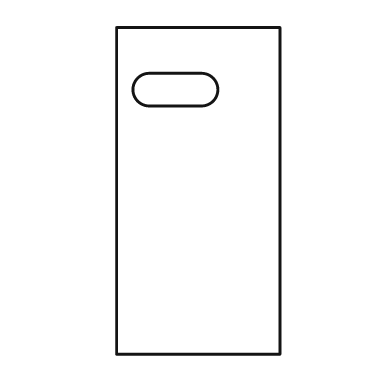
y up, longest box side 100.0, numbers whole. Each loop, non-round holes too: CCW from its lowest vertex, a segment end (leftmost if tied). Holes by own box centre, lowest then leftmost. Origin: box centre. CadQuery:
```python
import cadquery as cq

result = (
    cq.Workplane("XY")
    .moveTo(-25.0, -50.0)
    .lineTo(25.0, -50.0)
    .lineTo(25.0, 50.0)
    .lineTo(-25.0, 50.0)
    .close()
    .moveTo(-15.0, 26.0)
    .lineTo(1.0, 26.0)
    .threePointArc((6.0, 31.0), (1.0, 36.0))
    .lineTo(-15.0, 36.0)
    .threePointArc((-20.0, 31.0), (-15.0, 26.0))
    .close()
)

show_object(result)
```